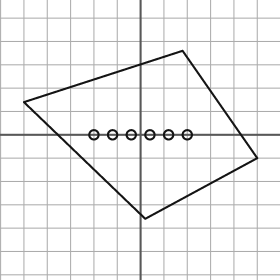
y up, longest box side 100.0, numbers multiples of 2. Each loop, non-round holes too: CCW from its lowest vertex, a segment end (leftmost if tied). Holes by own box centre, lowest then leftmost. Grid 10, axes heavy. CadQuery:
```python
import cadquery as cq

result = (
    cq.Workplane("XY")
    .moveTo(2.0, -36.0)
    .lineTo(50.0, -10.0)
    .lineTo(18.0, 36.0)
    .lineTo(-50.0, 14.0)
    .close()
    .moveTo(-20.0, 0.0)
    .circle(2.0)
    .moveTo(-12.0, 0.0)
    .circle(2.0)
    .moveTo(-4.0, 0.0)
    .circle(2.0)
    .moveTo(4.0, 0.0)
    .circle(2.0)
    .moveTo(12.0, 0.0)
    .circle(2.0)
    .moveTo(20.0, 0.0)
    .circle(2.0)
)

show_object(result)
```